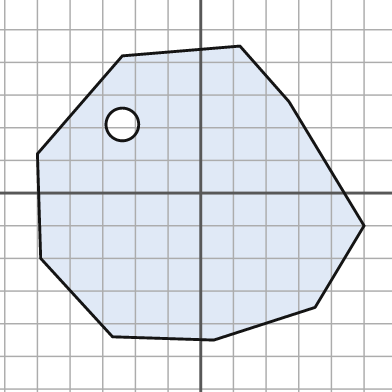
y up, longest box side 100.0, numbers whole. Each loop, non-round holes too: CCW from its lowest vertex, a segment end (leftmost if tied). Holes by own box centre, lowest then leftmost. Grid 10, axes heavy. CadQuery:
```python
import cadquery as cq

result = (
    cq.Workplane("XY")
    .moveTo(4.0, -45.0)
    .lineTo(35.0, -35.0)
    .lineTo(50.0, -10.0)
    .lineTo(27.0, 28.0)
    .lineTo(12.0, 45.0)
    .lineTo(-24.0, 42.0)
    .lineTo(-50.0, 12.0)
    .lineTo(-49.0, -20.0)
    .lineTo(-27.0, -44.0)
    .close()
    .moveTo(-24.0, 21.0)
    .circle(5.0)
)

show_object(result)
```